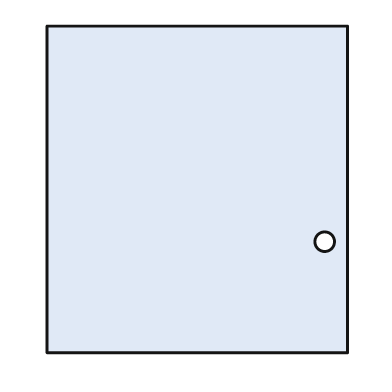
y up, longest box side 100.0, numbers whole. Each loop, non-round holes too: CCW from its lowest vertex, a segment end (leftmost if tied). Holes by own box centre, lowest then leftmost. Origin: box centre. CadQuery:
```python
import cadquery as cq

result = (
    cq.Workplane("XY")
    .moveTo(-46.0, -50.0)
    .lineTo(46.0, -50.0)
    .lineTo(46.0, 50.0)
    .lineTo(-46.0, 50.0)
    .close()
    .moveTo(39.0, -16.0)
    .circle(3.0)
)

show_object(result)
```